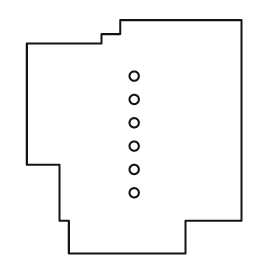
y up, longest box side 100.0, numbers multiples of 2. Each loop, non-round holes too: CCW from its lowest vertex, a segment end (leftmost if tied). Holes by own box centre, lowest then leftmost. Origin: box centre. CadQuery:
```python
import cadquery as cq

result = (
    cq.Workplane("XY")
    .moveTo(-28.0, -50.0)
    .lineTo(22.0, -50.0)
    .lineTo(22.0, -36.0)
    .lineTo(46.0, -36.0)
    .lineTo(46.0, 50.0)
    .lineTo(-6.0, 50.0)
    .lineTo(-6.0, 44.0)
    .lineTo(-14.0, 44.0)
    .lineTo(-14.0, 40.0)
    .lineTo(-46.0, 40.0)
    .lineTo(-46.0, -12.0)
    .lineTo(-32.0, -12.0)
    .lineTo(-32.0, -36.0)
    .lineTo(-28.0, -36.0)
    .close()
    .moveTo(0.0, -24.0)
    .circle(2.0)
    .moveTo(0.0, -14.0)
    .circle(2.0)
    .moveTo(0.0, -4.0)
    .circle(2.0)
    .moveTo(0.0, 6.0)
    .circle(2.0)
    .moveTo(0.0, 16.0)
    .circle(2.0)
    .moveTo(0.0, 26.0)
    .circle(2.0)
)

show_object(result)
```